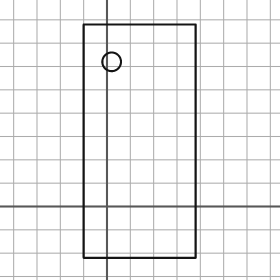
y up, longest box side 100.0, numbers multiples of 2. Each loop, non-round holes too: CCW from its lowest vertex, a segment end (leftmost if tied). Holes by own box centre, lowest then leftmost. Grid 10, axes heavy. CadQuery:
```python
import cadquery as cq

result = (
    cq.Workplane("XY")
    .moveTo(-10.0, -22.0)
    .lineTo(38.0, -22.0)
    .lineTo(38.0, 78.0)
    .lineTo(-10.0, 78.0)
    .close()
    .moveTo(2.0, 62.0)
    .circle(4.0)
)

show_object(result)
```